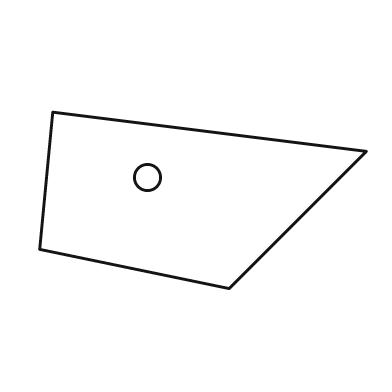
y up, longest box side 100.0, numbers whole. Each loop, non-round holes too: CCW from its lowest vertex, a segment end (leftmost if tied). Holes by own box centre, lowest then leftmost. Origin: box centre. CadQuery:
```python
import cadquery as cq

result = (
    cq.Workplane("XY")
    .moveTo(8.0, -27.0)
    .lineTo(50.0, 15.0)
    .lineTo(-46.0, 27.0)
    .lineTo(-50.0, -15.0)
    .close()
    .moveTo(-17.0, 7.0)
    .circle(4.0)
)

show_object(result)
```